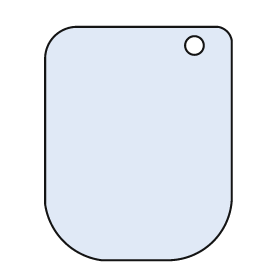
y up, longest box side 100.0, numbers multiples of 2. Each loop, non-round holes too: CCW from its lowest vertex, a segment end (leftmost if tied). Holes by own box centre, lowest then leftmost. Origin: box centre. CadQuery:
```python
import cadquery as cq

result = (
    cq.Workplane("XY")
    .moveTo(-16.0, -50.0)
    .lineTo(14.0, -50.0)
    .threePointArc((32.0, -42.0), (40.0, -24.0))
    .lineTo(40.0, 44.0)
    .threePointArc((38.0, 48.0), (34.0, 50.0))
    .lineTo(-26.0, 50.0)
    .threePointArc((-36.0, 46.0), (-40.0, 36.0))
    .lineTo(-40.0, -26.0)
    .threePointArc((-32.0, -42.0), (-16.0, -50.0))
    .close()
    .moveTo(24.0, 42.0)
    .circle(4.0)
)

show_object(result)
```